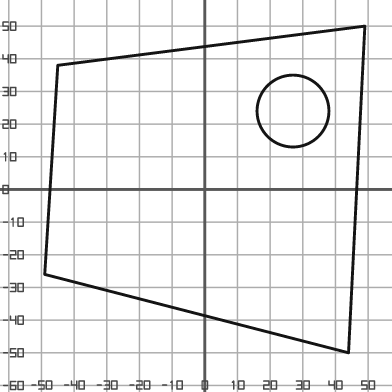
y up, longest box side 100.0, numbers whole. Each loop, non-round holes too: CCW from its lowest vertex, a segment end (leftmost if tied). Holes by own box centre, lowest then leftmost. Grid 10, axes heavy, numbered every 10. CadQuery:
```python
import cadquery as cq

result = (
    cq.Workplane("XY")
    .moveTo(44.0, -50.0)
    .lineTo(49.0, 50.0)
    .lineTo(-45.0, 38.0)
    .lineTo(-49.0, -26.0)
    .close()
    .moveTo(27.0, 24.0)
    .circle(11.0)
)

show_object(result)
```